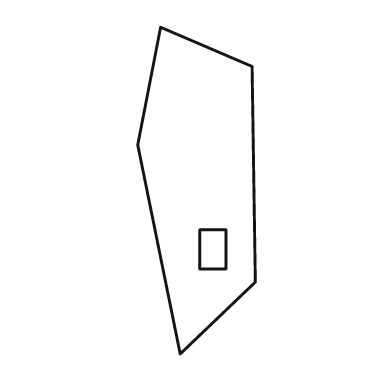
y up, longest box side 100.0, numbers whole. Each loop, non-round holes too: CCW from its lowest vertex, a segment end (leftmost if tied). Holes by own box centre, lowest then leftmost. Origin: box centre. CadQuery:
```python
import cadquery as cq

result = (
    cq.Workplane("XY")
    .moveTo(-5.0, -50.0)
    .lineTo(18.0, -28.0)
    .lineTo(17.0, 38.0)
    .lineTo(-11.0, 50.0)
    .lineTo(-18.0, 14.0)
    .close()
    .moveTo(1.0, -24.0)
    .lineTo(9.0, -24.0)
    .lineTo(9.0, -12.0)
    .lineTo(1.0, -12.0)
    .close()
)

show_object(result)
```